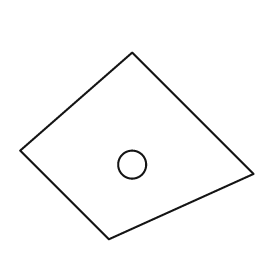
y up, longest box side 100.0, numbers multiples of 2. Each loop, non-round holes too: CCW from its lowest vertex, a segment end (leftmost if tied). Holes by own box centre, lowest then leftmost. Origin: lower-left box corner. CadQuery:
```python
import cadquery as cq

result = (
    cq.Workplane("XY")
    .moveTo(38.0, 0.0)
    .lineTo(100.0, 28.0)
    .lineTo(48.0, 80.0)
    .lineTo(0.0, 38.0)
    .close()
    .moveTo(48.0, 32.0)
    .circle(6.0)
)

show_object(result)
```